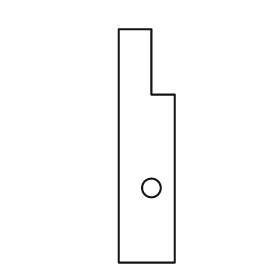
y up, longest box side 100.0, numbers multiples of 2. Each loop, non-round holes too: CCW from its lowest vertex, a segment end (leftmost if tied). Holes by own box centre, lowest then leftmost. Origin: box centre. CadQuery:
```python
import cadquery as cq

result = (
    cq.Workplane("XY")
    .moveTo(-12.0, -50.0)
    .lineTo(12.0, -50.0)
    .lineTo(12.0, 22.0)
    .lineTo(2.0, 22.0)
    .lineTo(2.0, 50.0)
    .lineTo(-12.0, 50.0)
    .close()
    .moveTo(2.0, -18.0)
    .circle(4.0)
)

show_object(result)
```